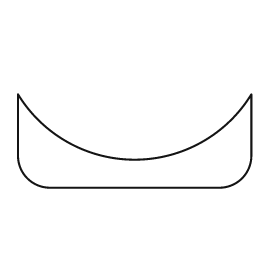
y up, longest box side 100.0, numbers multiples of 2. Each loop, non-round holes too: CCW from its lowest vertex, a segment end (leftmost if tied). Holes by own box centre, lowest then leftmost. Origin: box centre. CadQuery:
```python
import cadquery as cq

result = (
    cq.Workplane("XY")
    .moveTo(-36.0, -20.0)
    .lineTo(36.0, -20.0)
    .threePointArc((46.0, -16.0), (50.0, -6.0))
    .lineTo(50.0, 20.0)
    .threePointArc((0.0, -8.0), (-50.0, 20.0))
    .lineTo(-50.0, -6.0)
    .threePointArc((-46.0, -16.0), (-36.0, -20.0))
    .close()
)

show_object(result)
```